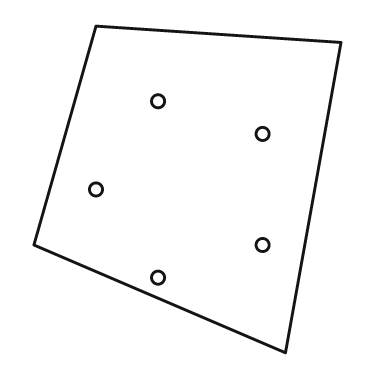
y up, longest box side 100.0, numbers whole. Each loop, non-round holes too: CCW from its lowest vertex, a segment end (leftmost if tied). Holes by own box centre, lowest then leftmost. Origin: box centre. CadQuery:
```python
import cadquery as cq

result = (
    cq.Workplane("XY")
    .moveTo(30.0, -50.0)
    .lineTo(47.0, 45.0)
    .lineTo(-28.0, 50.0)
    .lineTo(-47.0, -17.0)
    .close()
    .moveTo(-9.0, -27.0)
    .circle(2.0)
    .moveTo(23.0, -17.0)
    .circle(2.0)
    .moveTo(-28.0, 0.0)
    .circle(2.0)
    .moveTo(23.0, 17.0)
    .circle(2.0)
    .moveTo(-9.0, 27.0)
    .circle(2.0)
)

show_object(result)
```